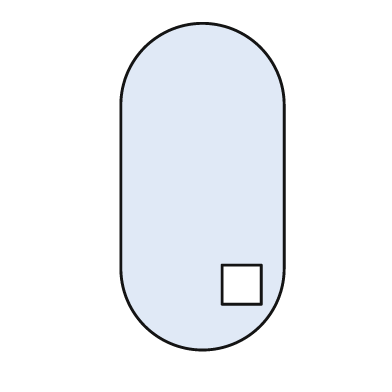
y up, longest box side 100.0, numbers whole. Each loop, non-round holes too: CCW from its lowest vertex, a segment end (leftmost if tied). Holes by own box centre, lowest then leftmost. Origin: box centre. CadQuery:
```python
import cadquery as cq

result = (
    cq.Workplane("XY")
    .moveTo(-25.0, -25.0)
    .threePointArc((0.0, -50.0), (25.0, -25.0))
    .lineTo(25.0, 25.0)
    .threePointArc((0.0, 50.0), (-25.0, 25.0))
    .close()
    .moveTo(6.0, -36.0)
    .lineTo(18.0, -36.0)
    .lineTo(18.0, -24.0)
    .lineTo(6.0, -24.0)
    .close()
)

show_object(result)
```